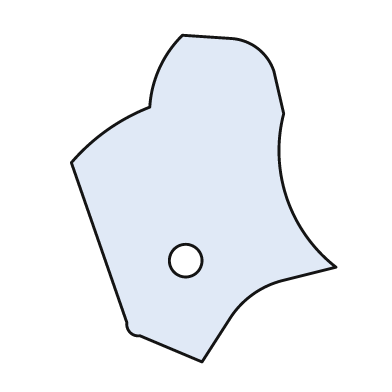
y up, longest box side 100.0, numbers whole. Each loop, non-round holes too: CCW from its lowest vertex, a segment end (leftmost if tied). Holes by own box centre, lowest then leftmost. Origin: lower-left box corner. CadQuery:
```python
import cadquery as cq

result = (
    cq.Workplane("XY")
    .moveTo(40.0, 0.0)
    .lineTo(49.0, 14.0)
    .threePointArc((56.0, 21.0), (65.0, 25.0))
    .lineTo(81.0, 29.0)
    .threePointArc((66.0, 50.0), (65.0, 76.0))
    .lineTo(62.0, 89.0)
    .threePointArc((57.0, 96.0), (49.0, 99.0))
    .lineTo(34.0, 100.0)
    .threePointArc((27.0, 90.0), (24.0, 78.0))
    .threePointArc((11.0, 71.0), (0.0, 61.0))
    .lineTo(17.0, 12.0)
    .threePointArc((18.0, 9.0), (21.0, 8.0))
    .close()
    .moveTo(35.0, 31.0)
    .circle(5.0)
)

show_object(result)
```